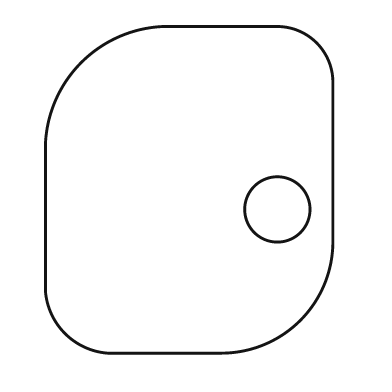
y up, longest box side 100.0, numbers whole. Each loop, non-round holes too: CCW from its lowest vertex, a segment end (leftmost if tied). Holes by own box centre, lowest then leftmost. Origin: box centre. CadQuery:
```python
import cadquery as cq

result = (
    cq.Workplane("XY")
    .moveTo(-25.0, -50.0)
    .lineTo(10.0, -50.0)
    .threePointArc((34.0, -40.0), (44.0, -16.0))
    .lineTo(44.0, 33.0)
    .threePointArc((39.0, 45.0), (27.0, 50.0))
    .lineTo(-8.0, 50.0)
    .threePointArc((-33.0, 39.0), (-44.0, 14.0))
    .lineTo(-44.0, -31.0)
    .threePointArc((-38.0, -44.0), (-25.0, -50.0))
    .close()
    .moveTo(27.0, -6.0)
    .circle(10.0)
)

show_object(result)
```